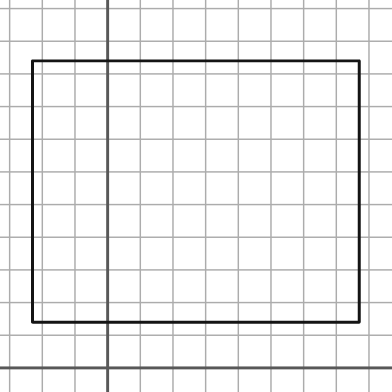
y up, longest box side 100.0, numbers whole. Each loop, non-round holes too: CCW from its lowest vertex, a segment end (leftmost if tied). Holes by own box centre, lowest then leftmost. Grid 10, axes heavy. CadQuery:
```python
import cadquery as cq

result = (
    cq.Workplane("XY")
    .moveTo(-23.0, 14.0)
    .lineTo(77.0, 14.0)
    .lineTo(77.0, 94.0)
    .lineTo(-23.0, 94.0)
    .close()
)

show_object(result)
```